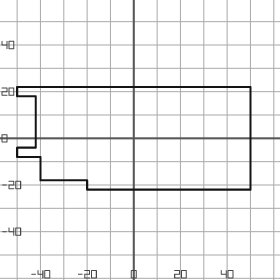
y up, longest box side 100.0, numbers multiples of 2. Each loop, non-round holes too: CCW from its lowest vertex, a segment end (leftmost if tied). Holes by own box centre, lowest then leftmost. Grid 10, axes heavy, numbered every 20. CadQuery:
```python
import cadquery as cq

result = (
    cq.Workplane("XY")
    .moveTo(-20.0, -22.0)
    .lineTo(50.0, -22.0)
    .lineTo(50.0, 22.0)
    .lineTo(-50.0, 22.0)
    .lineTo(-50.0, 18.0)
    .lineTo(-42.0, 18.0)
    .lineTo(-42.0, -4.0)
    .lineTo(-50.0, -4.0)
    .lineTo(-50.0, -8.0)
    .lineTo(-40.0, -8.0)
    .lineTo(-40.0, -18.0)
    .lineTo(-20.0, -18.0)
    .close()
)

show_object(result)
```